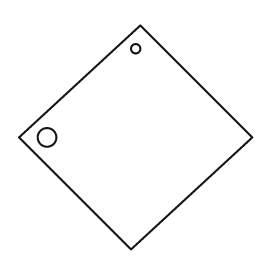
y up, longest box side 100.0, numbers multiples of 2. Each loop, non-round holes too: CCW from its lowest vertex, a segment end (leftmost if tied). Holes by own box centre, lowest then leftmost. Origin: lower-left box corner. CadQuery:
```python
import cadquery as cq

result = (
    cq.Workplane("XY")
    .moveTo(48.0, 0.0)
    .lineTo(100.0, 48.0)
    .lineTo(52.0, 96.0)
    .lineTo(0.0, 48.0)
    .close()
    .moveTo(12.0, 48.0)
    .circle(4.0)
    .moveTo(50.0, 86.0)
    .circle(2.0)
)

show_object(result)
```